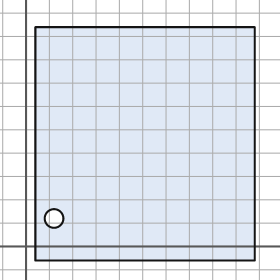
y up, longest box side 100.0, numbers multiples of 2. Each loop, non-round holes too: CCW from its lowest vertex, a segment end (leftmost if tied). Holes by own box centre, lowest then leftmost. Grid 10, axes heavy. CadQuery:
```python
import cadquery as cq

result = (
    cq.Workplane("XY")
    .moveTo(4.0, -6.0)
    .lineTo(98.0, -6.0)
    .lineTo(98.0, 94.0)
    .lineTo(4.0, 94.0)
    .close()
    .moveTo(12.0, 12.0)
    .circle(4.0)
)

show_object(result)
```